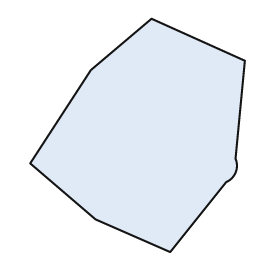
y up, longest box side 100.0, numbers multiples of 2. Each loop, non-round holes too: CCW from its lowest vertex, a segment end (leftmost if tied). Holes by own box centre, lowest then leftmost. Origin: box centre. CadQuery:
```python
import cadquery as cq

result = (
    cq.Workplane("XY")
    .moveTo(14.0, -50.0)
    .lineTo(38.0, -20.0)
    .threePointArc((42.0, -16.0), (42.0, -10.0))
    .lineTo(46.0, 32.0)
    .lineTo(6.0, 50.0)
    .lineTo(-20.0, 28.0)
    .lineTo(-46.0, -12.0)
    .lineTo(-18.0, -36.0)
    .close()
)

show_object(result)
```